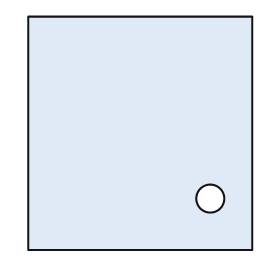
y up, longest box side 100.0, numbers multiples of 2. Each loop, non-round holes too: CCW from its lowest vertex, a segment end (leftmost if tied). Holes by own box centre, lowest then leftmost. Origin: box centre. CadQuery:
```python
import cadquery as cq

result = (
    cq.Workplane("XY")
    .moveTo(-48.0, -50.0)
    .lineTo(48.0, -50.0)
    .lineTo(48.0, 50.0)
    .lineTo(-48.0, 50.0)
    .close()
    .moveTo(30.0, -28.0)
    .circle(6.0)
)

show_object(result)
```